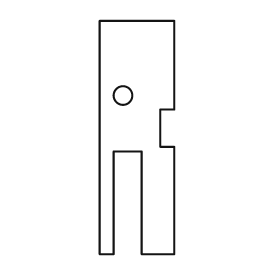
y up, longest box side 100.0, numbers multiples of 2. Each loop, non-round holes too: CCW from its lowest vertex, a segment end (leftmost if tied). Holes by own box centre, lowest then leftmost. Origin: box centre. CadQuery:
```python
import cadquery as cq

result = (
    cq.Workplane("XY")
    .moveTo(-16.0, -50.0)
    .lineTo(-10.0, -50.0)
    .lineTo(-10.0, -6.0)
    .lineTo(2.0, -6.0)
    .lineTo(2.0, -50.0)
    .lineTo(16.0, -50.0)
    .lineTo(16.0, -4.0)
    .lineTo(10.0, -4.0)
    .lineTo(10.0, 12.0)
    .lineTo(16.0, 12.0)
    .lineTo(16.0, 50.0)
    .lineTo(-16.0, 50.0)
    .close()
    .moveTo(-6.0, 18.0)
    .circle(4.0)
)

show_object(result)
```